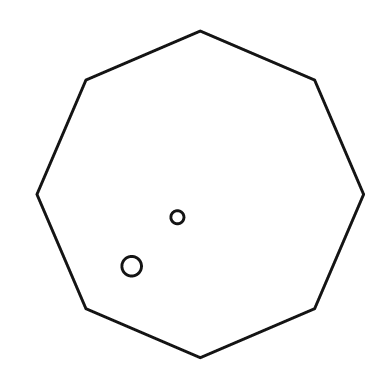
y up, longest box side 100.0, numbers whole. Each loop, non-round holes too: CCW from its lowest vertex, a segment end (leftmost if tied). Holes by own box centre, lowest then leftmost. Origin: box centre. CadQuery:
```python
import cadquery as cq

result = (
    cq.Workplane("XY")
    .moveTo(0.0, -50.0)
    .lineTo(35.0, -35.0)
    .lineTo(50.0, 0.0)
    .lineTo(35.0, 35.0)
    .lineTo(0.0, 50.0)
    .lineTo(-35.0, 35.0)
    .lineTo(-50.0, 0.0)
    .lineTo(-35.0, -35.0)
    .close()
    .moveTo(-21.0, -22.0)
    .circle(3.0)
    .moveTo(-7.0, -7.0)
    .circle(2.0)
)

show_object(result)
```